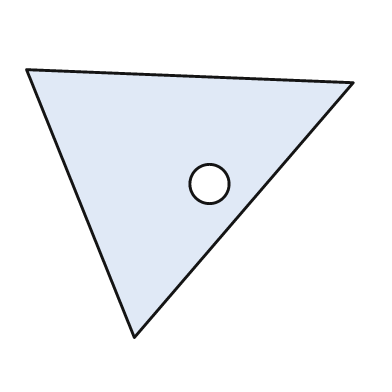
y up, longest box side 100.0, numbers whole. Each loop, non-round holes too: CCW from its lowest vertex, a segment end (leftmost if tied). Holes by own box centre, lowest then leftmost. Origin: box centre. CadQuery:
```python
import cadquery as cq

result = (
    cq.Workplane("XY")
    .moveTo(-17.0, -41.0)
    .lineTo(50.0, 37.0)
    .lineTo(-50.0, 41.0)
    .close()
    .moveTo(6.0, 6.0)
    .circle(6.0)
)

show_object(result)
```